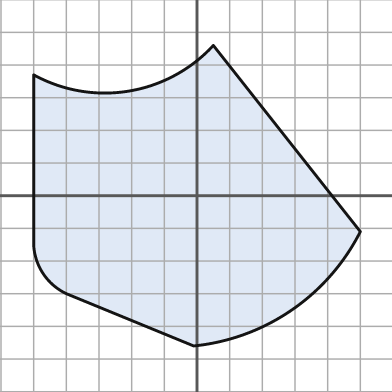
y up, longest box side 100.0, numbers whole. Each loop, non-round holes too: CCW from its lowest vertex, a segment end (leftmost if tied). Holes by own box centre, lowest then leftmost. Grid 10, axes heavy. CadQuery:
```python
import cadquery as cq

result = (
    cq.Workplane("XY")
    .moveTo(-1.0, -46.0)
    .threePointArc((29.0, -35.0), (50.0, -11.0))
    .lineTo(5.0, 46.0)
    .threePointArc((-21.0, 32.0), (-50.0, 37.0))
    .lineTo(-50.0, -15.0)
    .threePointArc((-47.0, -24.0), (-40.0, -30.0))
    .close()
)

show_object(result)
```